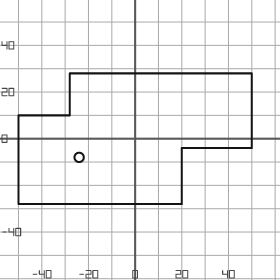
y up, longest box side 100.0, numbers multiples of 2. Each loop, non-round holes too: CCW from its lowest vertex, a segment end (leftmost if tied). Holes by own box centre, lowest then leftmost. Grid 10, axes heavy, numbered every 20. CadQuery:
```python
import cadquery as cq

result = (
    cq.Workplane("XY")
    .moveTo(-50.0, -28.0)
    .lineTo(20.0, -28.0)
    .lineTo(20.0, -4.0)
    .lineTo(50.0, -4.0)
    .lineTo(50.0, 28.0)
    .lineTo(-28.0, 28.0)
    .lineTo(-28.0, 10.0)
    .lineTo(-50.0, 10.0)
    .close()
    .moveTo(-24.0, -8.0)
    .circle(2.0)
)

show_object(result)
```